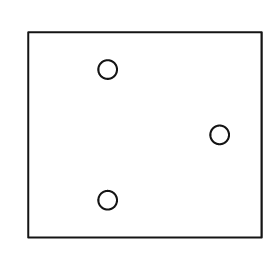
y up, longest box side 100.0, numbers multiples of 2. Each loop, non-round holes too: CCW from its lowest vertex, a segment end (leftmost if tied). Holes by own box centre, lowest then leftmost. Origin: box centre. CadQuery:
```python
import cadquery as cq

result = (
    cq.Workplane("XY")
    .moveTo(-50.0, -44.0)
    .lineTo(50.0, -44.0)
    .lineTo(50.0, 44.0)
    .lineTo(-50.0, 44.0)
    .close()
    .moveTo(-16.0, -28.0)
    .circle(4.0)
    .moveTo(32.0, 0.0)
    .circle(4.0)
    .moveTo(-16.0, 28.0)
    .circle(4.0)
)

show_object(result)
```